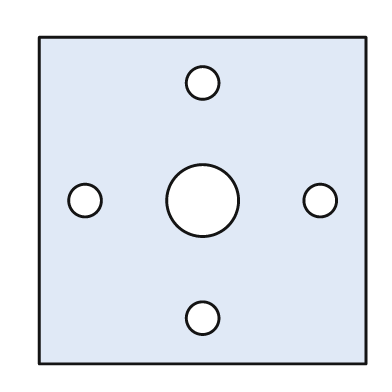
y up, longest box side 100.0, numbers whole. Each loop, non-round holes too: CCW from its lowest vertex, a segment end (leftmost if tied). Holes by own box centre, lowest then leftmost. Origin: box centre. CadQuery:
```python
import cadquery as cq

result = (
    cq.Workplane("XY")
    .moveTo(-50.0, -50.0)
    .lineTo(50.0, -50.0)
    .lineTo(50.0, 50.0)
    .lineTo(-50.0, 50.0)
    .close()
    .moveTo(0.0, -36.0)
    .circle(5.0)
    .moveTo(-36.0, 0.0)
    .circle(5.0)
    .moveTo(0.0, 0.0)
    .circle(11.0)
    .moveTo(36.0, 0.0)
    .circle(5.0)
    .moveTo(0.0, 36.0)
    .circle(5.0)
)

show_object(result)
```